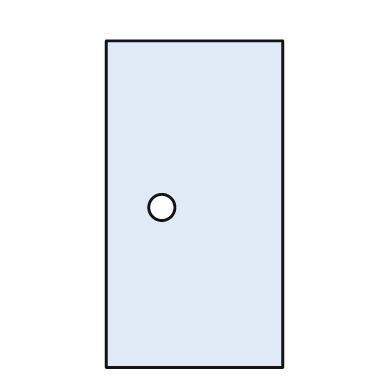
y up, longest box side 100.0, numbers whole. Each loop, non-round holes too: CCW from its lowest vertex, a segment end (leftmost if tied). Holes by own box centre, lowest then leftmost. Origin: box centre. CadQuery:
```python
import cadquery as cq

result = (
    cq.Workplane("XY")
    .moveTo(-27.0, -50.0)
    .lineTo(27.0, -50.0)
    .lineTo(27.0, 50.0)
    .lineTo(-27.0, 50.0)
    .close()
    .moveTo(-10.0, -1.0)
    .circle(4.0)
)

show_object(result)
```